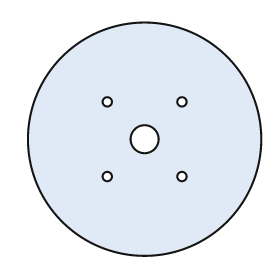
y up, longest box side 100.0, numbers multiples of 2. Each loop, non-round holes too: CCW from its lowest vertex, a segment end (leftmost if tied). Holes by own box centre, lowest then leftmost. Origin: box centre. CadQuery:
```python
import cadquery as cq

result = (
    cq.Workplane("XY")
    .moveTo(0.0, 0.0)
    .circle(50.0)
    .moveTo(-16.0, -16.0)
    .circle(2.0)
    .moveTo(16.0, -16.0)
    .circle(2.0)
    .moveTo(0.0, 0.0)
    .circle(6.0)
    .moveTo(-16.0, 16.0)
    .circle(2.0)
    .moveTo(16.0, 16.0)
    .circle(2.0)
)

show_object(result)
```